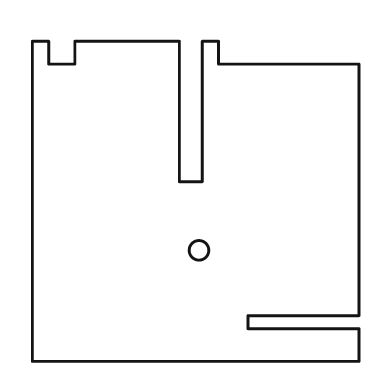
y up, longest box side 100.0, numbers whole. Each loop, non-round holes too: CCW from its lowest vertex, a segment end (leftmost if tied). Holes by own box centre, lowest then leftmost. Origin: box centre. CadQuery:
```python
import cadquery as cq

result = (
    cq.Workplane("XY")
    .moveTo(-50.0, -49.0)
    .lineTo(50.0, -49.0)
    .lineTo(50.0, -39.0)
    .lineTo(16.0, -39.0)
    .lineTo(16.0, -35.0)
    .lineTo(50.0, -35.0)
    .lineTo(50.0, 42.0)
    .lineTo(7.0, 42.0)
    .lineTo(7.0, 49.0)
    .lineTo(2.0, 49.0)
    .lineTo(2.0, 6.0)
    .lineTo(-5.0, 6.0)
    .lineTo(-5.0, 49.0)
    .lineTo(-37.0, 49.0)
    .lineTo(-37.0, 42.0)
    .lineTo(-45.0, 42.0)
    .lineTo(-45.0, 49.0)
    .lineTo(-50.0, 49.0)
    .close()
    .moveTo(1.0, -15.0)
    .circle(3.0)
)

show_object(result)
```